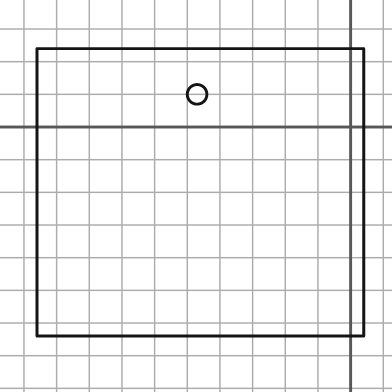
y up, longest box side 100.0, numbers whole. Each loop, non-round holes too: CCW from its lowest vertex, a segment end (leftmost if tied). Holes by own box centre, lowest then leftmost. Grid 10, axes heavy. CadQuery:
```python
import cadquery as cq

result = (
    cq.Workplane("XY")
    .moveTo(-96.0, -64.0)
    .lineTo(4.0, -64.0)
    .lineTo(4.0, 24.0)
    .lineTo(-96.0, 24.0)
    .close()
    .moveTo(-47.0, 10.0)
    .circle(3.0)
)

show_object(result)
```